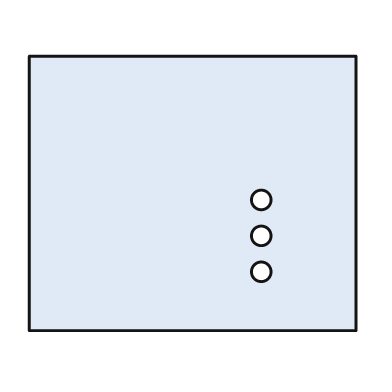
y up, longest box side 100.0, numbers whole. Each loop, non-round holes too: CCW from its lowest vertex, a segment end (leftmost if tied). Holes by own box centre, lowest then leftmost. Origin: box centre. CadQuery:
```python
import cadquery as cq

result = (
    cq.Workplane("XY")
    .moveTo(-50.0, -42.0)
    .lineTo(50.0, -42.0)
    .lineTo(50.0, 42.0)
    .lineTo(-50.0, 42.0)
    .close()
    .moveTo(21.0, -24.0)
    .circle(3.0)
    .moveTo(21.0, -13.0)
    .circle(3.0)
    .moveTo(21.0, -2.0)
    .circle(3.0)
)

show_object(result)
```